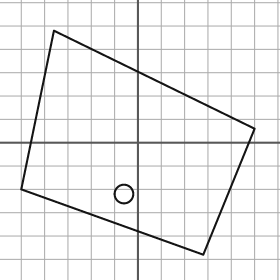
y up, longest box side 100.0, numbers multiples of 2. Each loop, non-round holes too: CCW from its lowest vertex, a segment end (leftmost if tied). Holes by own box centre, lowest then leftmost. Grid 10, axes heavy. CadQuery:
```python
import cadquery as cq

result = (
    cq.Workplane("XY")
    .moveTo(28.0, -48.0)
    .lineTo(50.0, 6.0)
    .lineTo(-36.0, 48.0)
    .lineTo(-50.0, -20.0)
    .close()
    .moveTo(-6.0, -22.0)
    .circle(4.0)
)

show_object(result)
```